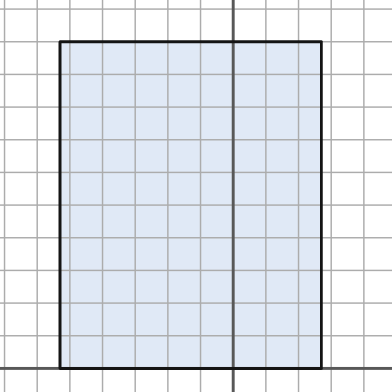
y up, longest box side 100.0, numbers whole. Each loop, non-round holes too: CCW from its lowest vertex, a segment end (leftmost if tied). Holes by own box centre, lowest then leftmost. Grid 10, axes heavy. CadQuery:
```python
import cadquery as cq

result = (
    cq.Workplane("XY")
    .moveTo(-53.0, 0.0)
    .lineTo(27.0, 0.0)
    .lineTo(27.0, 100.0)
    .lineTo(-53.0, 100.0)
    .close()
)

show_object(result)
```